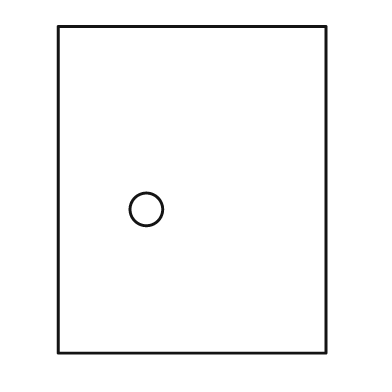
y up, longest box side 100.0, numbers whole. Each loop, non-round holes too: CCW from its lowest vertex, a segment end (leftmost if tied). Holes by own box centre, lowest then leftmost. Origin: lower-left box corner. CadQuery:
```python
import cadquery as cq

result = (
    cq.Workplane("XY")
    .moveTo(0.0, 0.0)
    .lineTo(82.0, 0.0)
    .lineTo(82.0, 100.0)
    .lineTo(0.0, 100.0)
    .close()
    .moveTo(27.0, 44.0)
    .circle(5.0)
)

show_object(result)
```